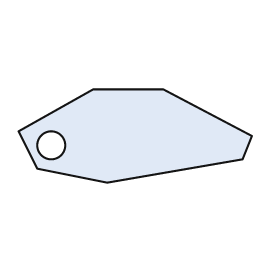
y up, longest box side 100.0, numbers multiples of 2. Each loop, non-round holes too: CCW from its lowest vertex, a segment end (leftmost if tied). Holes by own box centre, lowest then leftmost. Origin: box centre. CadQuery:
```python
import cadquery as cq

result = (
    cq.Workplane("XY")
    .moveTo(-12.0, -20.0)
    .lineTo(46.0, -10.0)
    .lineTo(50.0, 0.0)
    .lineTo(12.0, 20.0)
    .lineTo(-18.0, 20.0)
    .lineTo(-50.0, 2.0)
    .lineTo(-42.0, -14.0)
    .close()
    .moveTo(-36.0, -4.0)
    .circle(6.0)
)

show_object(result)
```